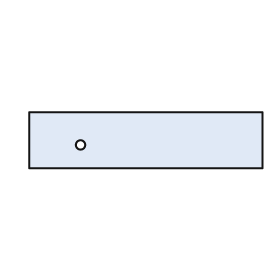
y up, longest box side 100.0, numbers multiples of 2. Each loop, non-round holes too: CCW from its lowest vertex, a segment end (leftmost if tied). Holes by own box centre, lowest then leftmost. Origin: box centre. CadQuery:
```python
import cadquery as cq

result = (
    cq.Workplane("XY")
    .moveTo(-50.0, -12.0)
    .lineTo(50.0, -12.0)
    .lineTo(50.0, 12.0)
    .lineTo(-50.0, 12.0)
    .close()
    .moveTo(-28.0, -2.0)
    .circle(2.0)
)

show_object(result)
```